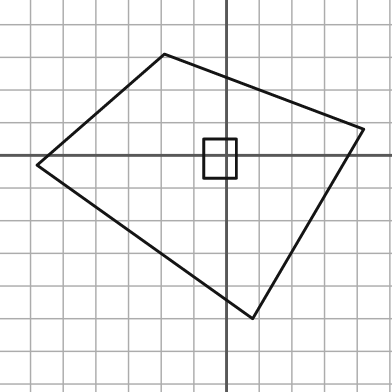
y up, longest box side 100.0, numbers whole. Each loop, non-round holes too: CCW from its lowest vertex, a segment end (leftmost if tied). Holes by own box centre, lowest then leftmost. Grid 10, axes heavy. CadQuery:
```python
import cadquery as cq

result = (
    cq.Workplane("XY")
    .moveTo(8.0, -50.0)
    .lineTo(42.0, 8.0)
    .lineTo(-19.0, 31.0)
    .lineTo(-58.0, -3.0)
    .close()
    .moveTo(-7.0, -7.0)
    .lineTo(3.0, -7.0)
    .lineTo(3.0, 5.0)
    .lineTo(-7.0, 5.0)
    .close()
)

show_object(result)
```